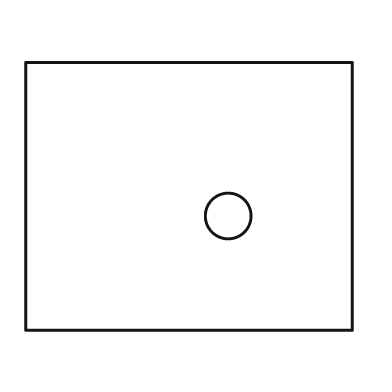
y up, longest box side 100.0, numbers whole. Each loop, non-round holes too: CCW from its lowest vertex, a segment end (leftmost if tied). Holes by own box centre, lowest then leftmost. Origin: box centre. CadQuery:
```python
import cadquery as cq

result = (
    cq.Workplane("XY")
    .moveTo(-50.0, -41.0)
    .lineTo(50.0, -41.0)
    .lineTo(50.0, 41.0)
    .lineTo(-50.0, 41.0)
    .close()
    .moveTo(12.0, -6.0)
    .circle(7.0)
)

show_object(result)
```